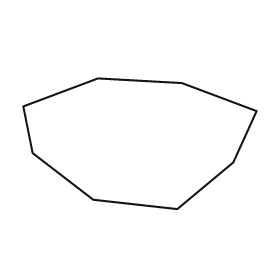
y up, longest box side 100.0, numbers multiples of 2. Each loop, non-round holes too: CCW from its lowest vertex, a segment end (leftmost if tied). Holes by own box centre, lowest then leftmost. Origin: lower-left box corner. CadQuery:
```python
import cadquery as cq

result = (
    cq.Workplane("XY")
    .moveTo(66.0, 0.0)
    .lineTo(90.0, 20.0)
    .lineTo(100.0, 42.0)
    .lineTo(68.0, 54.0)
    .lineTo(32.0, 56.0)
    .lineTo(0.0, 44.0)
    .lineTo(4.0, 24.0)
    .lineTo(30.0, 4.0)
    .close()
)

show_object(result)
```